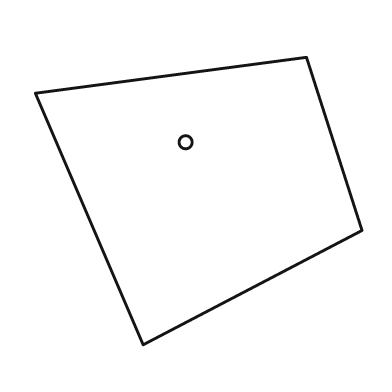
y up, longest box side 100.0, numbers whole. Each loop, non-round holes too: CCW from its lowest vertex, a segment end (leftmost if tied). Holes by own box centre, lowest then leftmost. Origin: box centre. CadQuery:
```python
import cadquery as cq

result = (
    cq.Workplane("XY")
    .moveTo(-17.0, -44.0)
    .lineTo(50.0, -9.0)
    .lineTo(33.0, 44.0)
    .lineTo(-50.0, 33.0)
    .close()
    .moveTo(-4.0, 18.0)
    .circle(2.0)
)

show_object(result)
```